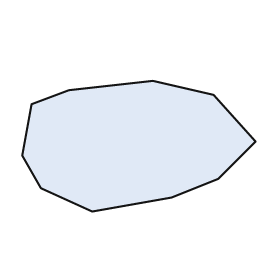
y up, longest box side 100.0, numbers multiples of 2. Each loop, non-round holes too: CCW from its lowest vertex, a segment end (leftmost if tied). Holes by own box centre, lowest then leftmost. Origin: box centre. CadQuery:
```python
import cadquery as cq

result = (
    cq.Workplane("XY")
    .moveTo(-20.0, -28.0)
    .lineTo(14.0, -22.0)
    .lineTo(34.0, -14.0)
    .lineTo(50.0, 2.0)
    .lineTo(32.0, 22.0)
    .lineTo(6.0, 28.0)
    .lineTo(-30.0, 24.0)
    .lineTo(-46.0, 18.0)
    .lineTo(-50.0, -4.0)
    .lineTo(-42.0, -18.0)
    .close()
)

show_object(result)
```